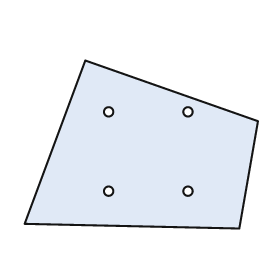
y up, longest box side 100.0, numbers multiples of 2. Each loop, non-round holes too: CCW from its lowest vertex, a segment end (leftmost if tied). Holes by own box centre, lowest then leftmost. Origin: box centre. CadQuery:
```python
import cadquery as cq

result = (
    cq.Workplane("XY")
    .moveTo(42.0, -36.0)
    .lineTo(50.0, 10.0)
    .lineTo(-24.0, 36.0)
    .lineTo(-50.0, -34.0)
    .close()
    .moveTo(-14.0, -20.0)
    .circle(2.0)
    .moveTo(20.0, -20.0)
    .circle(2.0)
    .moveTo(-14.0, 14.0)
    .circle(2.0)
    .moveTo(20.0, 14.0)
    .circle(2.0)
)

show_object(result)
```